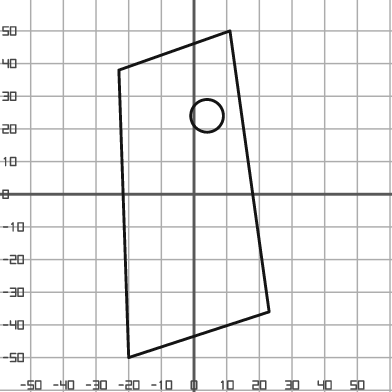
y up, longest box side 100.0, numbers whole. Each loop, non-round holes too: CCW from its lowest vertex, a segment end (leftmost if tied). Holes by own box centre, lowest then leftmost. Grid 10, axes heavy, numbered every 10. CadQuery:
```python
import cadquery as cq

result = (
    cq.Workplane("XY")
    .moveTo(-20.0, -50.0)
    .lineTo(23.0, -36.0)
    .lineTo(11.0, 50.0)
    .lineTo(-23.0, 38.0)
    .close()
    .moveTo(4.0, 24.0)
    .circle(5.0)
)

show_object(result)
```